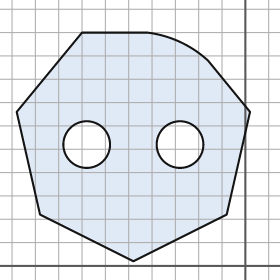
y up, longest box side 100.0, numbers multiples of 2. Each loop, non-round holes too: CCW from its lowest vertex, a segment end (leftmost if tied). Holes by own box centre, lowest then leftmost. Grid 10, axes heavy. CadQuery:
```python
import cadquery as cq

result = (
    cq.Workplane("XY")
    .moveTo(-48.0, 2.0)
    .lineTo(-8.0, 22.0)
    .lineTo(2.0, 66.0)
    .lineTo(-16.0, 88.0)
    .threePointArc((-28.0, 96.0), (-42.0, 100.0))
    .lineTo(-70.0, 100.0)
    .lineTo(-98.0, 66.0)
    .lineTo(-88.0, 22.0)
    .close()
    .moveTo(-68.0, 52.0)
    .circle(10.0)
    .moveTo(-28.0, 52.0)
    .circle(10.0)
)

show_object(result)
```